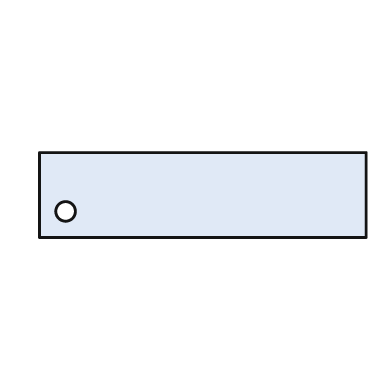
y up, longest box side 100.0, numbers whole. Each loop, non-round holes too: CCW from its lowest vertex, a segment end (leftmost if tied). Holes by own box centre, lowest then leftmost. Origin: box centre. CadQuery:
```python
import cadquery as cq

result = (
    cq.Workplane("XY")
    .moveTo(-50.0, -13.0)
    .lineTo(50.0, -13.0)
    .lineTo(50.0, 13.0)
    .lineTo(-50.0, 13.0)
    .close()
    .moveTo(-42.0, -5.0)
    .circle(3.0)
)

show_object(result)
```